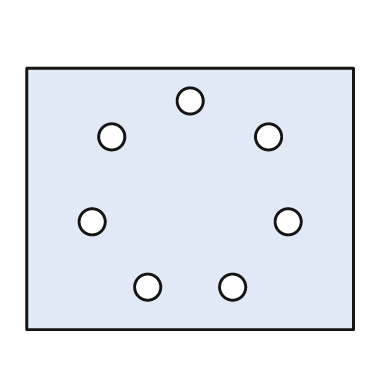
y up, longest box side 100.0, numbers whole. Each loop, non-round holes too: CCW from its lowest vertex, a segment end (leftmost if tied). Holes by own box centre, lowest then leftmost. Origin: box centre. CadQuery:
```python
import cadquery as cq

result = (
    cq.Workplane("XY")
    .moveTo(-50.0, -40.0)
    .lineTo(50.0, -40.0)
    .lineTo(50.0, 40.0)
    .lineTo(-50.0, 40.0)
    .close()
    .moveTo(-13.0, -27.0)
    .circle(4.0)
    .moveTo(13.0, -27.0)
    .circle(4.0)
    .moveTo(-30.0, -7.0)
    .circle(4.0)
    .moveTo(30.0, -7.0)
    .circle(4.0)
    .moveTo(-24.0, 19.0)
    .circle(4.0)
    .moveTo(24.0, 19.0)
    .circle(4.0)
    .moveTo(0.0, 30.0)
    .circle(4.0)
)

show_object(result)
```